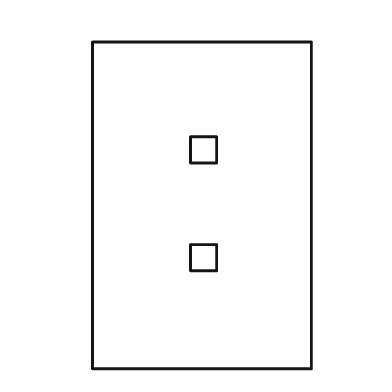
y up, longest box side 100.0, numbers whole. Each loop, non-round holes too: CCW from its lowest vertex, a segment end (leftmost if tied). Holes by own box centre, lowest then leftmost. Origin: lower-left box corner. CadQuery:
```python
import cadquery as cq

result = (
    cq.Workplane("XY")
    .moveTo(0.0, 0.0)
    .lineTo(67.0, 0.0)
    .lineTo(67.0, 100.0)
    .lineTo(0.0, 100.0)
    .close()
    .moveTo(30.0, 30.0)
    .lineTo(38.0, 30.0)
    .lineTo(38.0, 38.0)
    .lineTo(30.0, 38.0)
    .close()
    .moveTo(30.0, 63.0)
    .lineTo(38.0, 63.0)
    .lineTo(38.0, 71.0)
    .lineTo(30.0, 71.0)
    .close()
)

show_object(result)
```